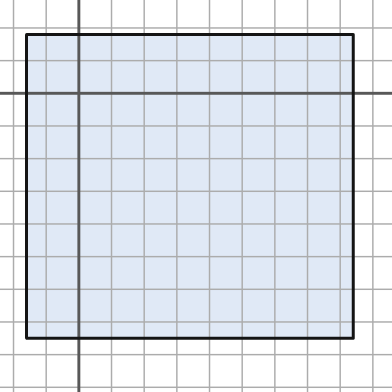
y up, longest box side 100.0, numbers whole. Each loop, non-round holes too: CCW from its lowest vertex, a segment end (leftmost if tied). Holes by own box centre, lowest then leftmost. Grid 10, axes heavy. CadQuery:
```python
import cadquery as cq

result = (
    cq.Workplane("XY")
    .moveTo(-16.0, -75.0)
    .lineTo(84.0, -75.0)
    .lineTo(84.0, 18.0)
    .lineTo(-16.0, 18.0)
    .close()
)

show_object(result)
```